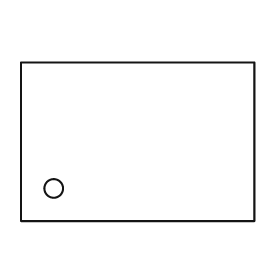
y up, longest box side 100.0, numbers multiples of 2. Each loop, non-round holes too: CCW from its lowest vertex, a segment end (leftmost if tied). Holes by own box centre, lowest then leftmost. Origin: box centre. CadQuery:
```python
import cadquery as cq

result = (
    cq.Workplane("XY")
    .moveTo(-50.0, -34.0)
    .lineTo(50.0, -34.0)
    .lineTo(50.0, 34.0)
    .lineTo(-50.0, 34.0)
    .close()
    .moveTo(-36.0, -20.0)
    .circle(4.0)
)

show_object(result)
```